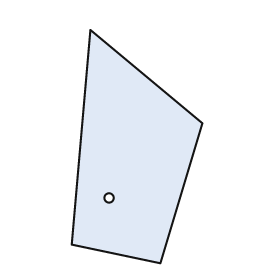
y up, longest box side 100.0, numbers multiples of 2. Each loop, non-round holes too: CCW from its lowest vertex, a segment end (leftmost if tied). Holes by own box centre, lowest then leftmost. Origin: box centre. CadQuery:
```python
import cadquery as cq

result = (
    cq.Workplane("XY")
    .moveTo(10.0, -50.0)
    .lineTo(28.0, 10.0)
    .lineTo(-20.0, 50.0)
    .lineTo(-28.0, -42.0)
    .close()
    .moveTo(-12.0, -22.0)
    .circle(2.0)
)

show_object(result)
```